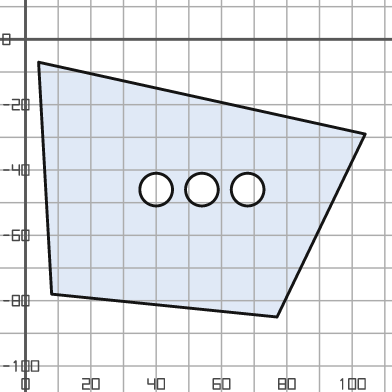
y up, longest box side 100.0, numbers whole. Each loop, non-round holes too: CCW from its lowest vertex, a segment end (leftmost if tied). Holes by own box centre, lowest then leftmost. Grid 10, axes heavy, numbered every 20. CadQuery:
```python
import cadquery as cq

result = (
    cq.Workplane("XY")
    .moveTo(77.0, -85.0)
    .lineTo(104.0, -29.0)
    .lineTo(4.0, -7.0)
    .lineTo(8.0, -78.0)
    .close()
    .moveTo(40.0, -46.0)
    .circle(5.0)
    .moveTo(54.0, -46.0)
    .circle(5.0)
    .moveTo(68.0, -46.0)
    .circle(5.0)
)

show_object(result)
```